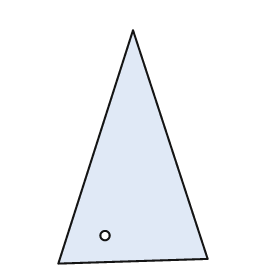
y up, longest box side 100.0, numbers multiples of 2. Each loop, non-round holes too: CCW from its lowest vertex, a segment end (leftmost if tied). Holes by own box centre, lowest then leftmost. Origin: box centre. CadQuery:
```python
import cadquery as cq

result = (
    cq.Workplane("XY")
    .moveTo(-32.0, -50.0)
    .lineTo(32.0, -48.0)
    .lineTo(0.0, 50.0)
    .close()
    .moveTo(-12.0, -38.0)
    .circle(2.0)
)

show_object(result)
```